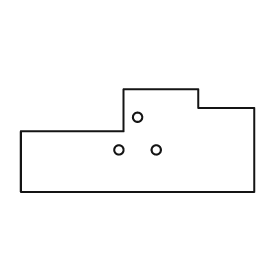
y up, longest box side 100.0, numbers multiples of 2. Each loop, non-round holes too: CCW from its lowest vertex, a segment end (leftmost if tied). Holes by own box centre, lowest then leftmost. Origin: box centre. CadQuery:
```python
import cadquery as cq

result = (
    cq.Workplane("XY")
    .moveTo(-50.0, -22.0)
    .lineTo(50.0, -22.0)
    .lineTo(50.0, 14.0)
    .lineTo(26.0, 14.0)
    .lineTo(26.0, 22.0)
    .lineTo(-6.0, 22.0)
    .lineTo(-6.0, 4.0)
    .lineTo(-50.0, 4.0)
    .close()
    .moveTo(-8.0, -4.0)
    .circle(2.0)
    .moveTo(8.0, -4.0)
    .circle(2.0)
    .moveTo(0.0, 10.0)
    .circle(2.0)
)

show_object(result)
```